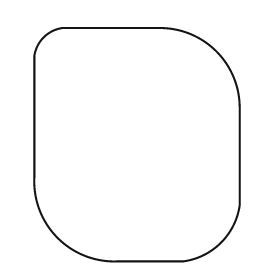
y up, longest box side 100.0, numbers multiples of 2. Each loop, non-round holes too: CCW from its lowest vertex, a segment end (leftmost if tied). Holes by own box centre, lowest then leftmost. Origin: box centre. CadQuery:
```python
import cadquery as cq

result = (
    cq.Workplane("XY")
    .moveTo(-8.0, -50.0)
    .lineTo(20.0, -50.0)
    .threePointArc((36.0, -42.0), (44.0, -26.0))
    .lineTo(44.0, 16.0)
    .threePointArc((34.0, 40.0), (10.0, 50.0))
    .lineTo(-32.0, 50.0)
    .threePointArc((-40.0, 46.0), (-44.0, 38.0))
    .lineTo(-44.0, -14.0)
    .threePointArc((-34.0, -40.0), (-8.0, -50.0))
    .close()
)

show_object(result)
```